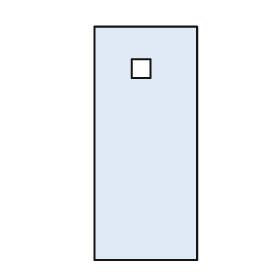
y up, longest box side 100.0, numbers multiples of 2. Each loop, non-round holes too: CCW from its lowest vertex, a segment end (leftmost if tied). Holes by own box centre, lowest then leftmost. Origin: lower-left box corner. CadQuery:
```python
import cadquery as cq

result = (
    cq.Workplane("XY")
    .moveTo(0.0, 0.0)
    .lineTo(44.0, 0.0)
    .lineTo(44.0, 100.0)
    .lineTo(0.0, 100.0)
    .close()
    .moveTo(16.0, 78.0)
    .lineTo(24.0, 78.0)
    .lineTo(24.0, 86.0)
    .lineTo(16.0, 86.0)
    .close()
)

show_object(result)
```